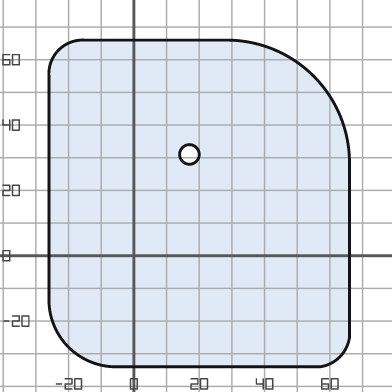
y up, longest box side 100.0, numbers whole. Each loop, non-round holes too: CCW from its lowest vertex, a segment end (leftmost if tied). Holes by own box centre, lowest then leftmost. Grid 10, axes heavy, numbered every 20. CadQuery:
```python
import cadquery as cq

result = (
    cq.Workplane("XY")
    .moveTo(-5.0, -34.0)
    .lineTo(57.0, -34.0)
    .threePointArc((63.0, -31.0), (66.0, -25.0))
    .lineTo(66.0, 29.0)
    .threePointArc((55.0, 55.0), (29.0, 66.0))
    .lineTo(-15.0, 66.0)
    .threePointArc((-23.0, 63.0), (-26.0, 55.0))
    .lineTo(-26.0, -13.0)
    .threePointArc((-20.0, -28.0), (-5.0, -34.0))
    .close()
    .moveTo(17.0, 31.0)
    .circle(3.0)
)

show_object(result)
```